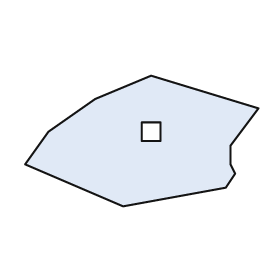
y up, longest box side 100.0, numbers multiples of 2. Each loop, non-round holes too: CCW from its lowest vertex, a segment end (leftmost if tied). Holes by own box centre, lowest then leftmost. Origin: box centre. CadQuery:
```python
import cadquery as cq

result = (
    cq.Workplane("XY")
    .moveTo(-8.0, -28.0)
    .lineTo(36.0, -20.0)
    .lineTo(40.0, -14.0)
    .lineTo(38.0, -10.0)
    .lineTo(38.0, -2.0)
    .lineTo(50.0, 14.0)
    .lineTo(4.0, 28.0)
    .lineTo(-20.0, 18.0)
    .lineTo(-40.0, 4.0)
    .lineTo(-50.0, -10.0)
    .close()
    .moveTo(0.0, 0.0)
    .lineTo(8.0, 0.0)
    .lineTo(8.0, 8.0)
    .lineTo(0.0, 8.0)
    .close()
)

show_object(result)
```